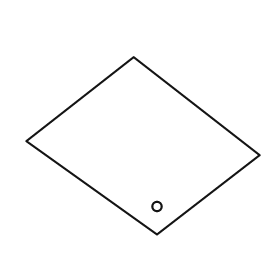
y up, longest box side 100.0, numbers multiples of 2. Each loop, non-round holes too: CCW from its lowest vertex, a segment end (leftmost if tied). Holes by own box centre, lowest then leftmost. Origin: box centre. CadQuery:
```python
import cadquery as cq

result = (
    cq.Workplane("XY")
    .moveTo(6.0, -38.0)
    .lineTo(50.0, -4.0)
    .lineTo(-4.0, 38.0)
    .lineTo(-50.0, 2.0)
    .close()
    .moveTo(6.0, -26.0)
    .circle(2.0)
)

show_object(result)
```